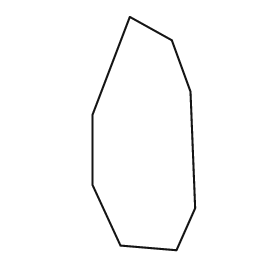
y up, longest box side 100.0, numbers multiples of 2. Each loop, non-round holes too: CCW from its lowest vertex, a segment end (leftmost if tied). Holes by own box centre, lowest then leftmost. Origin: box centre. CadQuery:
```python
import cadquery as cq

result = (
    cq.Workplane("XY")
    .moveTo(14.0, -50.0)
    .lineTo(22.0, -32.0)
    .lineTo(20.0, 18.0)
    .lineTo(12.0, 40.0)
    .lineTo(-6.0, 50.0)
    .lineTo(-22.0, 8.0)
    .lineTo(-22.0, -22.0)
    .lineTo(-10.0, -48.0)
    .close()
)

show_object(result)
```